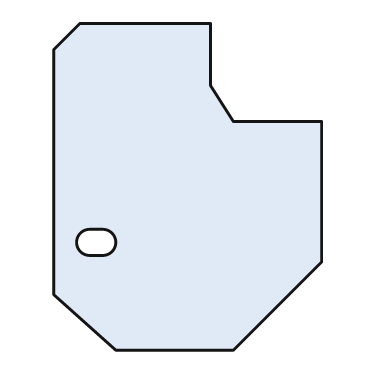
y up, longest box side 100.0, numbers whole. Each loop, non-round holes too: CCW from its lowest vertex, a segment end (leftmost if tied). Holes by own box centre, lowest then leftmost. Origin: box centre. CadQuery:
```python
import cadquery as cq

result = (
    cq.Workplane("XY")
    .moveTo(-22.0, -50.0)
    .lineTo(14.0, -50.0)
    .lineTo(41.0, -23.0)
    .lineTo(41.0, 20.0)
    .lineTo(14.0, 20.0)
    .lineTo(7.0, 31.0)
    .lineTo(7.0, 50.0)
    .lineTo(-33.0, 50.0)
    .lineTo(-41.0, 42.0)
    .lineTo(-41.0, -33.0)
    .close()
    .moveTo(-30.0, -21.0)
    .lineTo(-26.0, -21.0)
    .threePointArc((-22.0, -17.0), (-26.0, -13.0))
    .lineTo(-30.0, -13.0)
    .threePointArc((-34.0, -17.0), (-30.0, -21.0))
    .close()
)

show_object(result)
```